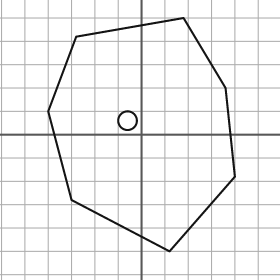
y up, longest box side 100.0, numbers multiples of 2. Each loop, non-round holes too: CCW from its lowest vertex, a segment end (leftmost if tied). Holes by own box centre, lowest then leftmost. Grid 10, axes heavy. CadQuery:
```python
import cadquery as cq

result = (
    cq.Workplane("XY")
    .moveTo(12.0, -50.0)
    .lineTo(40.0, -18.0)
    .lineTo(36.0, 20.0)
    .lineTo(18.0, 50.0)
    .lineTo(-28.0, 42.0)
    .lineTo(-40.0, 10.0)
    .lineTo(-30.0, -28.0)
    .close()
    .moveTo(-6.0, 6.0)
    .circle(4.0)
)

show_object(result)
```